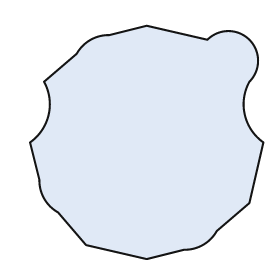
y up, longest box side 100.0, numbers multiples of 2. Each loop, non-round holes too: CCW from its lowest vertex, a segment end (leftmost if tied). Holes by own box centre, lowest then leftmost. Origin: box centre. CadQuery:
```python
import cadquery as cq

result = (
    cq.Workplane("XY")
    .moveTo(0.0, -50.0)
    .lineTo(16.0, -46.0)
    .threePointArc((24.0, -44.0), (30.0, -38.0))
    .lineTo(44.0, -26.0)
    .lineTo(50.0, 0.0)
    .threePointArc((42.0, 12.0), (44.0, 26.0))
    .threePointArc((44.0, 44.0), (26.0, 44.0))
    .lineTo(0.0, 50.0)
    .lineTo(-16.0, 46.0)
    .threePointArc((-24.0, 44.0), (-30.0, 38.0))
    .lineTo(-44.0, 26.0)
    .threePointArc((-42.0, 12.0), (-50.0, 0.0))
    .lineTo(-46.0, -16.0)
    .threePointArc((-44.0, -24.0), (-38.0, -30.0))
    .lineTo(-26.0, -44.0)
    .close()
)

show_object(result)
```